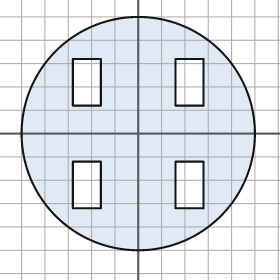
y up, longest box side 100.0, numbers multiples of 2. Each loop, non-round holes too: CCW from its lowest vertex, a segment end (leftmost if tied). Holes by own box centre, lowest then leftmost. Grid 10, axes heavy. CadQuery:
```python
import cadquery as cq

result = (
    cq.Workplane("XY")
    .moveTo(0.0, 0.0)
    .circle(50.0)
    .moveTo(-28.0, -32.0)
    .lineTo(-16.0, -32.0)
    .lineTo(-16.0, -12.0)
    .lineTo(-28.0, -12.0)
    .close()
    .moveTo(16.0, -32.0)
    .lineTo(28.0, -32.0)
    .lineTo(28.0, -12.0)
    .lineTo(16.0, -12.0)
    .close()
    .moveTo(-28.0, 12.0)
    .lineTo(-16.0, 12.0)
    .lineTo(-16.0, 32.0)
    .lineTo(-28.0, 32.0)
    .close()
    .moveTo(16.0, 12.0)
    .lineTo(28.0, 12.0)
    .lineTo(28.0, 32.0)
    .lineTo(16.0, 32.0)
    .close()
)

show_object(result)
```